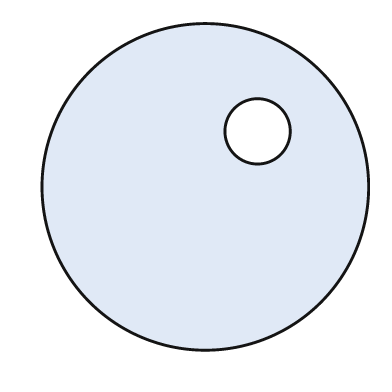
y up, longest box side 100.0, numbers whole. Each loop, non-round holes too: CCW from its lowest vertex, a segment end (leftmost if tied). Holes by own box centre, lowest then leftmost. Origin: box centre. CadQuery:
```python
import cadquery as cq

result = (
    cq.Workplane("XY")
    .moveTo(0.0, 0.0)
    .circle(50.0)
    .moveTo(16.0, 17.0)
    .circle(10.0)
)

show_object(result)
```